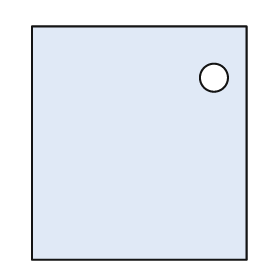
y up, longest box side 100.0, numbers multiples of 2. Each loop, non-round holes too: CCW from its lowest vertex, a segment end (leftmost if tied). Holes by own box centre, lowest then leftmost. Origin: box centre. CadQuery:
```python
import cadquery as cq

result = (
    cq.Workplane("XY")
    .moveTo(-46.0, -50.0)
    .lineTo(46.0, -50.0)
    .lineTo(46.0, 50.0)
    .lineTo(-46.0, 50.0)
    .close()
    .moveTo(32.0, 28.0)
    .circle(6.0)
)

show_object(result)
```